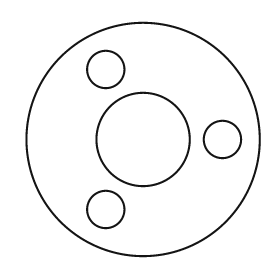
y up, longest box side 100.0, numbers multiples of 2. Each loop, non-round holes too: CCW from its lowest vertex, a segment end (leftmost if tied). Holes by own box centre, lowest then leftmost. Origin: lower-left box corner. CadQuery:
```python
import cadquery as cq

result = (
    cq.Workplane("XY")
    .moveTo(50.0, 50.0)
    .circle(50.0)
    .moveTo(34.0, 20.0)
    .circle(8.0)
    .moveTo(50.0, 50.0)
    .circle(20.0)
    .moveTo(84.0, 50.0)
    .circle(8.0)
    .moveTo(34.0, 80.0)
    .circle(8.0)
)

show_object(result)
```